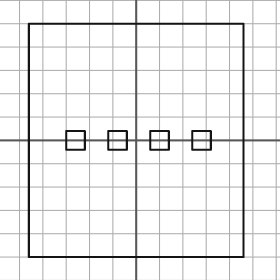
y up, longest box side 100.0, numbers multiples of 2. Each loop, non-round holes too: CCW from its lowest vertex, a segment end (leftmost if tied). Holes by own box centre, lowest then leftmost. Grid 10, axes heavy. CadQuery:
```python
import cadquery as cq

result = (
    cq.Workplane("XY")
    .moveTo(-46.0, -50.0)
    .lineTo(46.0, -50.0)
    .lineTo(46.0, 50.0)
    .lineTo(-46.0, 50.0)
    .close()
    .moveTo(-30.0, -4.0)
    .lineTo(-22.0, -4.0)
    .lineTo(-22.0, 4.0)
    .lineTo(-30.0, 4.0)
    .close()
    .moveTo(-12.0, -4.0)
    .lineTo(-4.0, -4.0)
    .lineTo(-4.0, 4.0)
    .lineTo(-12.0, 4.0)
    .close()
    .moveTo(6.0, -4.0)
    .lineTo(14.0, -4.0)
    .lineTo(14.0, 4.0)
    .lineTo(6.0, 4.0)
    .close()
    .moveTo(24.0, -4.0)
    .lineTo(32.0, -4.0)
    .lineTo(32.0, 4.0)
    .lineTo(24.0, 4.0)
    .close()
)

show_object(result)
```